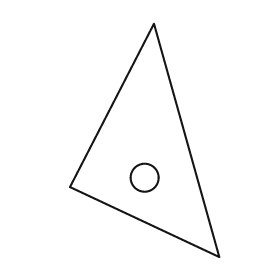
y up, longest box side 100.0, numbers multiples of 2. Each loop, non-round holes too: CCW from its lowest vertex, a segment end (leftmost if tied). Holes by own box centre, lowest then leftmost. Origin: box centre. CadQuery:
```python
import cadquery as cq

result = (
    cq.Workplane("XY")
    .moveTo(32.0, -50.0)
    .lineTo(4.0, 50.0)
    .lineTo(-32.0, -20.0)
    .close()
    .moveTo(0.0, -16.0)
    .circle(6.0)
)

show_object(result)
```